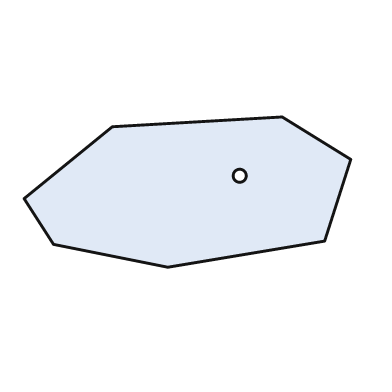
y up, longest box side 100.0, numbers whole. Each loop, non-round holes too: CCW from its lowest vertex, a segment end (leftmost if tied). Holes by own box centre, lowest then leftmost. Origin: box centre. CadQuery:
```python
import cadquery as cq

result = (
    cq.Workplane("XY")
    .moveTo(-6.0, -23.0)
    .lineTo(42.0, -15.0)
    .lineTo(50.0, 10.0)
    .lineTo(29.0, 23.0)
    .lineTo(-23.0, 20.0)
    .lineTo(-50.0, -2.0)
    .lineTo(-41.0, -16.0)
    .close()
    .moveTo(16.0, 5.0)
    .circle(2.0)
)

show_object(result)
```